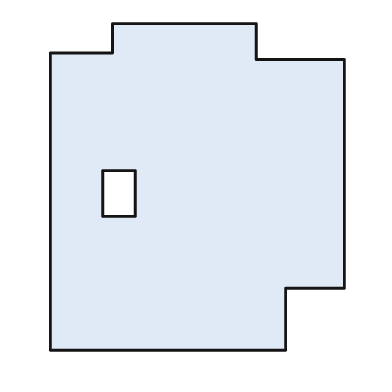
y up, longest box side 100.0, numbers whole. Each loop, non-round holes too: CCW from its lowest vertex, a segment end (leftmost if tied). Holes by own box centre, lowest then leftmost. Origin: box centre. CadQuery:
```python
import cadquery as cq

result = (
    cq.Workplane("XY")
    .moveTo(-45.0, -50.0)
    .lineTo(27.0, -50.0)
    .lineTo(27.0, -31.0)
    .lineTo(45.0, -31.0)
    .lineTo(45.0, 39.0)
    .lineTo(18.0, 39.0)
    .lineTo(18.0, 50.0)
    .lineTo(-26.0, 50.0)
    .lineTo(-26.0, 41.0)
    .lineTo(-45.0, 41.0)
    .close()
    .moveTo(-29.0, -9.0)
    .lineTo(-19.0, -9.0)
    .lineTo(-19.0, 5.0)
    .lineTo(-29.0, 5.0)
    .close()
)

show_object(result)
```